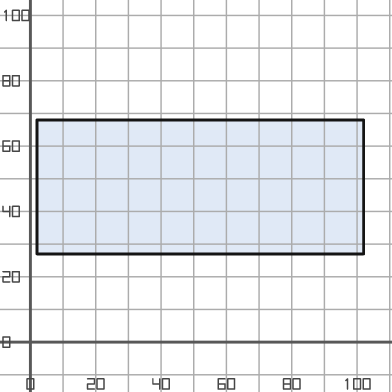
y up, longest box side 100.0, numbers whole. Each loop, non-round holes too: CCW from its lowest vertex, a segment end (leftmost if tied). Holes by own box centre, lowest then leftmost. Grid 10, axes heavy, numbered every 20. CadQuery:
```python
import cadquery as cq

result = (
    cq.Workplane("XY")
    .moveTo(2.0, 27.0)
    .lineTo(102.0, 27.0)
    .lineTo(102.0, 68.0)
    .lineTo(2.0, 68.0)
    .close()
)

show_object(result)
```